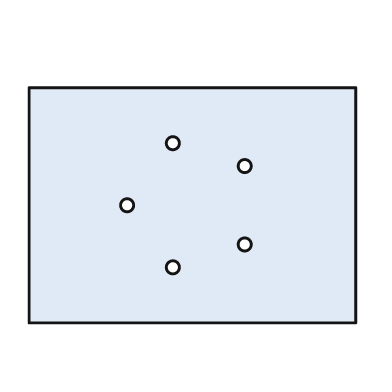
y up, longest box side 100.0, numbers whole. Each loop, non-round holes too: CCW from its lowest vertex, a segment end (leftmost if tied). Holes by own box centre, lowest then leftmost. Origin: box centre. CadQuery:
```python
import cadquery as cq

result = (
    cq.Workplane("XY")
    .moveTo(-50.0, -36.0)
    .lineTo(50.0, -36.0)
    .lineTo(50.0, 36.0)
    .lineTo(-50.0, 36.0)
    .close()
    .moveTo(-6.0, -19.0)
    .circle(2.0)
    .moveTo(16.0, -12.0)
    .circle(2.0)
    .moveTo(-20.0, 0.0)
    .circle(2.0)
    .moveTo(16.0, 12.0)
    .circle(2.0)
    .moveTo(-6.0, 19.0)
    .circle(2.0)
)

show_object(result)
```